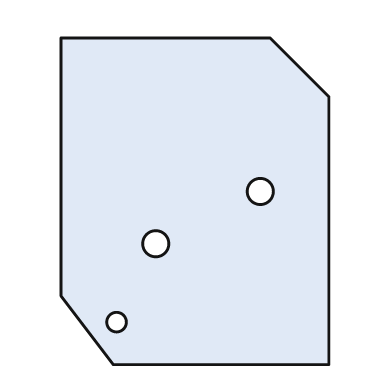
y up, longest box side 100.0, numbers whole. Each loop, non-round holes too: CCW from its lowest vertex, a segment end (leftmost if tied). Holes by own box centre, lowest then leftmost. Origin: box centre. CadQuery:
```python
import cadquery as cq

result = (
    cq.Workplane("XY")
    .moveTo(-25.0, -50.0)
    .lineTo(41.0, -50.0)
    .lineTo(41.0, 32.0)
    .lineTo(23.0, 50.0)
    .lineTo(-41.0, 50.0)
    .lineTo(-41.0, -29.0)
    .close()
    .moveTo(-24.0, -37.0)
    .circle(3.0)
    .moveTo(-12.0, -13.0)
    .circle(4.0)
    .moveTo(20.0, 3.0)
    .circle(4.0)
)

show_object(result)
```